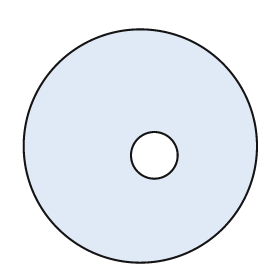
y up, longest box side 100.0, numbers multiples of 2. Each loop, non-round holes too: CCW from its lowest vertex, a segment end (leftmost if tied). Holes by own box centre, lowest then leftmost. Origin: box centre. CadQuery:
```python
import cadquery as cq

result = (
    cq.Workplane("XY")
    .moveTo(0.0, 0.0)
    .circle(50.0)
    .moveTo(6.0, -4.0)
    .circle(10.0)
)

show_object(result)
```